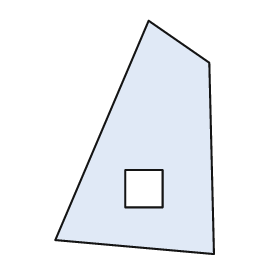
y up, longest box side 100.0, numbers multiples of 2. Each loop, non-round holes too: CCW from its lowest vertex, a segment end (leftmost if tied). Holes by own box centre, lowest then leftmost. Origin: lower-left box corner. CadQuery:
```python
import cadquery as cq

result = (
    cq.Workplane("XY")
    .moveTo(68.0, 0.0)
    .lineTo(66.0, 82.0)
    .lineTo(40.0, 100.0)
    .lineTo(0.0, 6.0)
    .close()
    .moveTo(30.0, 20.0)
    .lineTo(46.0, 20.0)
    .lineTo(46.0, 36.0)
    .lineTo(30.0, 36.0)
    .close()
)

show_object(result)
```